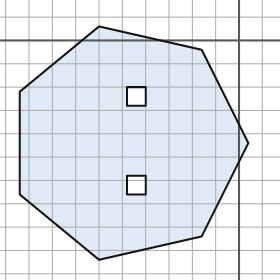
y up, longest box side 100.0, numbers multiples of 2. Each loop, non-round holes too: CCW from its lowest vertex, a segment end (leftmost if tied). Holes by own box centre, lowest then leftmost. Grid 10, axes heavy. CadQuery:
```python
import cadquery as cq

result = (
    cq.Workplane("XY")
    .moveTo(-60.0, -94.0)
    .lineTo(-16.0, -84.0)
    .lineTo(4.0, -44.0)
    .lineTo(-16.0, -4.0)
    .lineTo(-60.0, 6.0)
    .lineTo(-94.0, -22.0)
    .lineTo(-94.0, -66.0)
    .close()
    .moveTo(-48.0, -66.0)
    .lineTo(-40.0, -66.0)
    .lineTo(-40.0, -58.0)
    .lineTo(-48.0, -58.0)
    .close()
    .moveTo(-48.0, -28.0)
    .lineTo(-40.0, -28.0)
    .lineTo(-40.0, -20.0)
    .lineTo(-48.0, -20.0)
    .close()
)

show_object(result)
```